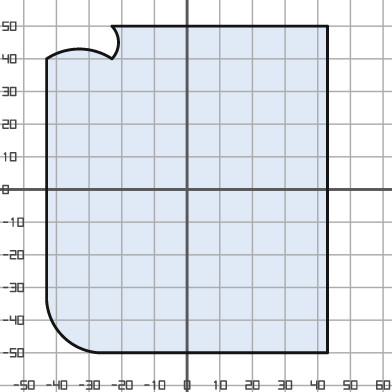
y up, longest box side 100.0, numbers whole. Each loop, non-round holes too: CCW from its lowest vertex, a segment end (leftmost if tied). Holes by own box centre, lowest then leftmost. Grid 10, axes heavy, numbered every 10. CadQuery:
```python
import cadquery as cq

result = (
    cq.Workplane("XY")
    .moveTo(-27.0, -50.0)
    .lineTo(43.0, -50.0)
    .lineTo(43.0, 50.0)
    .lineTo(-23.0, 50.0)
    .threePointArc((-21.0, 45.0), (-23.0, 40.0))
    .threePointArc((-33.0, 43.0), (-43.0, 40.0))
    .lineTo(-43.0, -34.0)
    .threePointArc((-38.0, -45.0), (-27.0, -50.0))
    .close()
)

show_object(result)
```